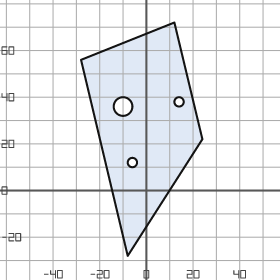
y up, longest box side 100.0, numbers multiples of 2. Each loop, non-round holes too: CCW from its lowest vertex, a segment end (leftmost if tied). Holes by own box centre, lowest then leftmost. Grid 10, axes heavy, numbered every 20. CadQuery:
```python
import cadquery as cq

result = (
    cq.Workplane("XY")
    .moveTo(-8.0, -28.0)
    .lineTo(24.0, 22.0)
    .lineTo(12.0, 72.0)
    .lineTo(-28.0, 56.0)
    .close()
    .moveTo(-6.0, 12.0)
    .circle(2.0)
    .moveTo(-10.0, 36.0)
    .circle(4.0)
    .moveTo(14.0, 38.0)
    .circle(2.0)
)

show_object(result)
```